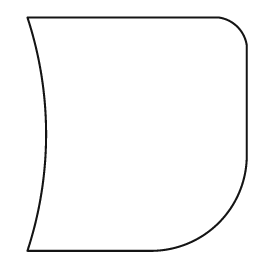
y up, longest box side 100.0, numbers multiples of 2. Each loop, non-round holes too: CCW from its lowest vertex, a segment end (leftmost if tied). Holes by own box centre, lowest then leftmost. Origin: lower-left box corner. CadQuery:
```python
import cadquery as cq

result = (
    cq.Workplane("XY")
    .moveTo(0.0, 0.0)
    .lineTo(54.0, 0.0)
    .threePointArc((82.0, 12.0), (94.0, 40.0))
    .lineTo(94.0, 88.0)
    .threePointArc((90.0, 96.0), (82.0, 100.0))
    .lineTo(0.0, 100.0)
    .threePointArc((8.0, 50.0), (0.0, 0.0))
    .close()
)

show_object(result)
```